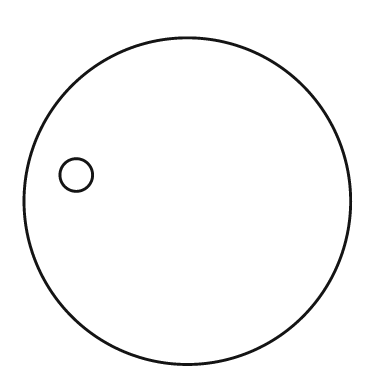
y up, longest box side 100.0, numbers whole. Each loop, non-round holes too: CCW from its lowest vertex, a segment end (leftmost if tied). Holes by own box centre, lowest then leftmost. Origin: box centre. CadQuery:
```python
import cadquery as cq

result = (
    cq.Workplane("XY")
    .moveTo(0.0, 0.0)
    .circle(50.0)
    .moveTo(-34.0, 8.0)
    .circle(5.0)
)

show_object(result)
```